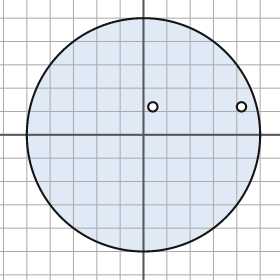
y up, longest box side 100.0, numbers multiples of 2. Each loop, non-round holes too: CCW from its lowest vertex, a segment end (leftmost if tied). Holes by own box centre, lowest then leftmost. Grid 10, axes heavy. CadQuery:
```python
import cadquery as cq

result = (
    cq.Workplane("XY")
    .moveTo(0.0, 0.0)
    .circle(50.0)
    .moveTo(4.0, 12.0)
    .circle(2.0)
    .moveTo(42.0, 12.0)
    .circle(2.0)
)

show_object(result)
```